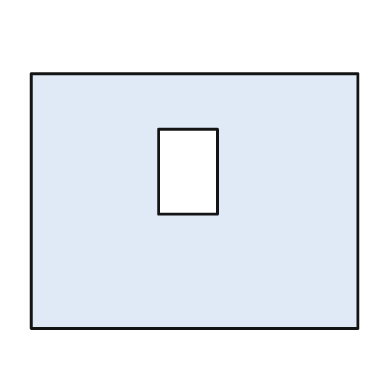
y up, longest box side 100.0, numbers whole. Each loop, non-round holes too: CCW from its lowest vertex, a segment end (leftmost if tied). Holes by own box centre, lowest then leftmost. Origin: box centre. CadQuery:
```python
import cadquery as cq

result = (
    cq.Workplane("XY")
    .moveTo(-50.0, -39.0)
    .lineTo(50.0, -39.0)
    .lineTo(50.0, 39.0)
    .lineTo(-50.0, 39.0)
    .close()
    .moveTo(-11.0, -4.0)
    .lineTo(7.0, -4.0)
    .lineTo(7.0, 22.0)
    .lineTo(-11.0, 22.0)
    .close()
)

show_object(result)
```